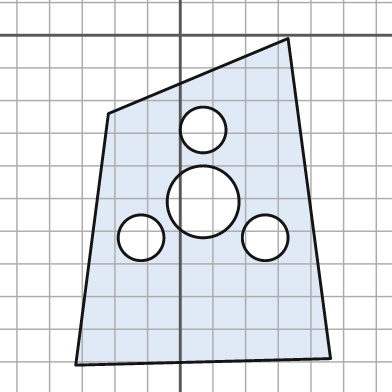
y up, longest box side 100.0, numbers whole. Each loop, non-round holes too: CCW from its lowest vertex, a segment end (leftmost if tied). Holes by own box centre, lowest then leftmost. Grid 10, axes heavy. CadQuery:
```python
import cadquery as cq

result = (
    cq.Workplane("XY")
    .moveTo(-32.0, -101.0)
    .lineTo(46.0, -99.0)
    .lineTo(33.0, -1.0)
    .lineTo(-22.0, -24.0)
    .close()
    .moveTo(-12.0, -62.0)
    .circle(7.0)
    .moveTo(26.0, -62.0)
    .circle(7.0)
    .moveTo(7.0, -51.0)
    .circle(11.0)
    .moveTo(7.0, -29.0)
    .circle(7.0)
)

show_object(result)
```